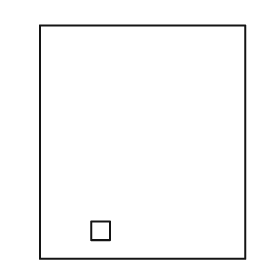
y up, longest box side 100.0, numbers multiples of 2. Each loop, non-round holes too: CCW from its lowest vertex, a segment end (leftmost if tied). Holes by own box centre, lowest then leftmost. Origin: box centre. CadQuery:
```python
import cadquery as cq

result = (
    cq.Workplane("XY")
    .moveTo(-44.0, -50.0)
    .lineTo(44.0, -50.0)
    .lineTo(44.0, 50.0)
    .lineTo(-44.0, 50.0)
    .close()
    .moveTo(-22.0, -42.0)
    .lineTo(-14.0, -42.0)
    .lineTo(-14.0, -34.0)
    .lineTo(-22.0, -34.0)
    .close()
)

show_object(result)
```